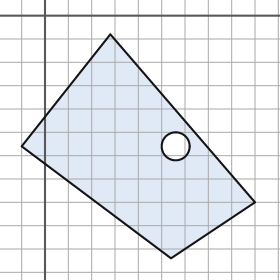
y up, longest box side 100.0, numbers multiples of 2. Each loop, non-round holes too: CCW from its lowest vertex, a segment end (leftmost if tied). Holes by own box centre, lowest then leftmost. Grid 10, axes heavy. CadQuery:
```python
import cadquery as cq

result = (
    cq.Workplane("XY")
    .moveTo(54.0, -104.0)
    .lineTo(90.0, -80.0)
    .lineTo(28.0, -8.0)
    .lineTo(-10.0, -56.0)
    .close()
    .moveTo(56.0, -56.0)
    .circle(6.0)
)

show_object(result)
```